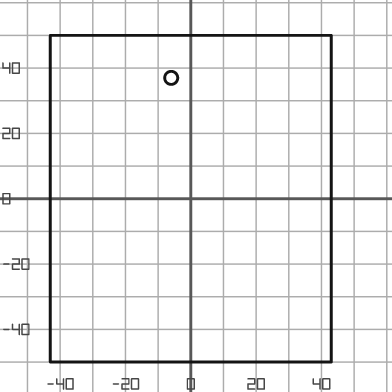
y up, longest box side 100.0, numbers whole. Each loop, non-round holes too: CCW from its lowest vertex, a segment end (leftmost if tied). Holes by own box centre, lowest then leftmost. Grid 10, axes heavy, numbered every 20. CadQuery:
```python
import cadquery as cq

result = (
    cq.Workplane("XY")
    .moveTo(-43.0, -50.0)
    .lineTo(43.0, -50.0)
    .lineTo(43.0, 50.0)
    .lineTo(-43.0, 50.0)
    .close()
    .moveTo(-6.0, 37.0)
    .circle(2.0)
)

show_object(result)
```